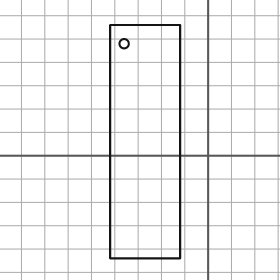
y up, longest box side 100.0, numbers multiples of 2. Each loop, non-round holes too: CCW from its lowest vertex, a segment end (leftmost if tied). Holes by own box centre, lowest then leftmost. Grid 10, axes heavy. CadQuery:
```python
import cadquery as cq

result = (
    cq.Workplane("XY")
    .moveTo(-42.0, -44.0)
    .lineTo(-12.0, -44.0)
    .lineTo(-12.0, 56.0)
    .lineTo(-42.0, 56.0)
    .close()
    .moveTo(-36.0, 48.0)
    .circle(2.0)
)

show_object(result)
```